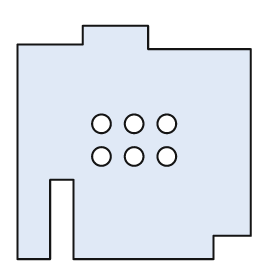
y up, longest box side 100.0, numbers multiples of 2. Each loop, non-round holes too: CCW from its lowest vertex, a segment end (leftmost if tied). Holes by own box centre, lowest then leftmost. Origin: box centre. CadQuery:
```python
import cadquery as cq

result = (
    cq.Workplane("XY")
    .moveTo(-50.0, -50.0)
    .lineTo(-36.0, -50.0)
    .lineTo(-36.0, -16.0)
    .lineTo(-26.0, -16.0)
    .lineTo(-26.0, -50.0)
    .lineTo(34.0, -50.0)
    .lineTo(34.0, -40.0)
    .lineTo(50.0, -40.0)
    .lineTo(50.0, 40.0)
    .lineTo(6.0, 40.0)
    .lineTo(6.0, 50.0)
    .lineTo(-22.0, 50.0)
    .lineTo(-22.0, 42.0)
    .lineTo(-50.0, 42.0)
    .close()
    .moveTo(-14.0, -6.0)
    .circle(4.0)
    .moveTo(0.0, -6.0)
    .circle(4.0)
    .moveTo(14.0, -6.0)
    .circle(4.0)
    .moveTo(-14.0, 8.0)
    .circle(4.0)
    .moveTo(0.0, 8.0)
    .circle(4.0)
    .moveTo(14.0, 8.0)
    .circle(4.0)
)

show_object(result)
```